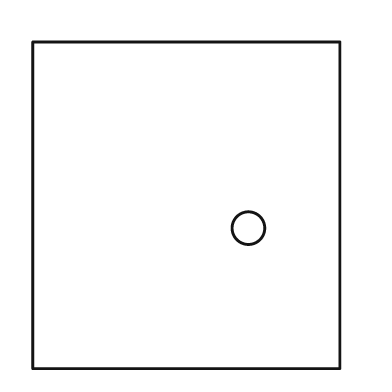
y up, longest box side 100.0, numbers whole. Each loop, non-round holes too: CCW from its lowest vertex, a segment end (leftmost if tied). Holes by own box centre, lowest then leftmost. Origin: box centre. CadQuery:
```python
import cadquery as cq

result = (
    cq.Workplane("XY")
    .moveTo(-47.0, -50.0)
    .lineTo(47.0, -50.0)
    .lineTo(47.0, 50.0)
    .lineTo(-47.0, 50.0)
    .close()
    .moveTo(19.0, -7.0)
    .circle(5.0)
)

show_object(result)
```